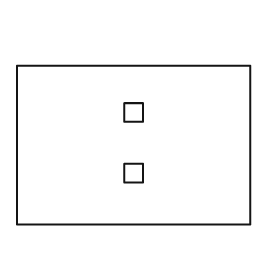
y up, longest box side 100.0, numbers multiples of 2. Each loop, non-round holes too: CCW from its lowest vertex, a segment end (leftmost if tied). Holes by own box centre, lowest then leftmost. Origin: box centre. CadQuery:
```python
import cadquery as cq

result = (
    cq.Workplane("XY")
    .moveTo(-50.0, -34.0)
    .lineTo(50.0, -34.0)
    .lineTo(50.0, 34.0)
    .lineTo(-50.0, 34.0)
    .close()
    .moveTo(-4.0, -16.0)
    .lineTo(4.0, -16.0)
    .lineTo(4.0, -8.0)
    .lineTo(-4.0, -8.0)
    .close()
    .moveTo(-4.0, 10.0)
    .lineTo(4.0, 10.0)
    .lineTo(4.0, 18.0)
    .lineTo(-4.0, 18.0)
    .close()
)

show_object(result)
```